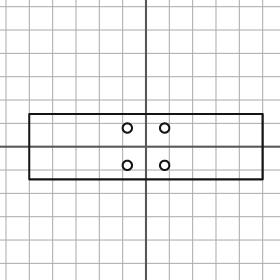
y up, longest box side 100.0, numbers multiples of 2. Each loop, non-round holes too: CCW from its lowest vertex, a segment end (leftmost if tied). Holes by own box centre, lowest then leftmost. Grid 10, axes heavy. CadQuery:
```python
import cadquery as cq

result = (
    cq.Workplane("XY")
    .moveTo(-50.0, -14.0)
    .lineTo(50.0, -14.0)
    .lineTo(50.0, 14.0)
    .lineTo(-50.0, 14.0)
    .close()
    .moveTo(-8.0, -8.0)
    .circle(2.0)
    .moveTo(8.0, -8.0)
    .circle(2.0)
    .moveTo(-8.0, 8.0)
    .circle(2.0)
    .moveTo(8.0, 8.0)
    .circle(2.0)
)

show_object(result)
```